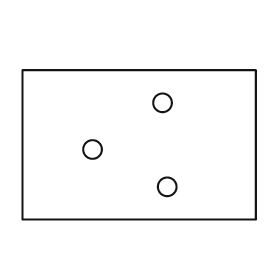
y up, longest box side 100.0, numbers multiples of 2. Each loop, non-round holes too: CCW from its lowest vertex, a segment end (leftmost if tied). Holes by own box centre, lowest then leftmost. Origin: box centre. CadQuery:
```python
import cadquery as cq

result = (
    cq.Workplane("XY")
    .moveTo(-50.0, -32.0)
    .lineTo(50.0, -32.0)
    .lineTo(50.0, 32.0)
    .lineTo(-50.0, 32.0)
    .close()
    .moveTo(12.0, -18.0)
    .circle(4.0)
    .moveTo(-20.0, -2.0)
    .circle(4.0)
    .moveTo(10.0, 18.0)
    .circle(4.0)
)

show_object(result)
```